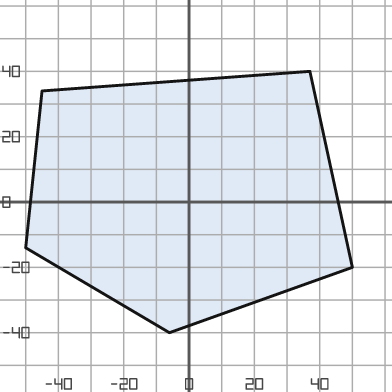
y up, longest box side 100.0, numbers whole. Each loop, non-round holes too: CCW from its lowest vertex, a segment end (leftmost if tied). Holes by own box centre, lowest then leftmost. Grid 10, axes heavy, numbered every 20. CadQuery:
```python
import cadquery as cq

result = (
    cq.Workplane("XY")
    .moveTo(-6.0, -40.0)
    .lineTo(50.0, -20.0)
    .lineTo(37.0, 40.0)
    .lineTo(-45.0, 34.0)
    .lineTo(-50.0, -14.0)
    .close()
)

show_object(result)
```